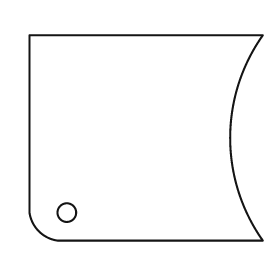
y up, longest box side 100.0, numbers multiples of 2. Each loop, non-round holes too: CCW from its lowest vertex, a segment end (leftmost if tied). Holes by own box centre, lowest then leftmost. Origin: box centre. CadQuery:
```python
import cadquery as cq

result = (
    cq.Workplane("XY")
    .moveTo(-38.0, -44.0)
    .lineTo(50.0, -44.0)
    .threePointArc((36.0, 0.0), (50.0, 44.0))
    .lineTo(-50.0, 44.0)
    .lineTo(-50.0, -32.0)
    .threePointArc((-46.0, -40.0), (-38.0, -44.0))
    .close()
    .moveTo(-34.0, -32.0)
    .circle(4.0)
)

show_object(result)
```